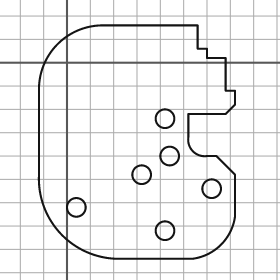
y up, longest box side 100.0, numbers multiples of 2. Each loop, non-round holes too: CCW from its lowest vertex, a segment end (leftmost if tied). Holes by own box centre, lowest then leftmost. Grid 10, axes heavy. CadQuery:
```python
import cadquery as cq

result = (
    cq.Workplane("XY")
    .moveTo(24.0, -84.0)
    .lineTo(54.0, -84.0)
    .threePointArc((66.0, -78.0), (72.0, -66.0))
    .lineTo(72.0, -48.0)
    .lineTo(64.0, -40.0)
    .lineTo(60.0, -40.0)
    .threePointArc((54.0, -38.0), (52.0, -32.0))
    .lineTo(52.0, -22.0)
    .lineTo(68.0, -22.0)
    .lineTo(72.0, -18.0)
    .lineTo(72.0, -12.0)
    .lineTo(68.0, -12.0)
    .lineTo(68.0, 2.0)
    .lineTo(60.0, 2.0)
    .lineTo(60.0, 6.0)
    .lineTo(56.0, 6.0)
    .lineTo(56.0, 16.0)
    .lineTo(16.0, 16.0)
    .threePointArc((-4.0, 8.0), (-12.0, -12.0))
    .lineTo(-12.0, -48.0)
    .threePointArc((-2.0, -74.0), (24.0, -84.0))
    .close()
    .moveTo(42.0, -72.0)
    .circle(4.0)
    .moveTo(4.0, -62.0)
    .circle(4.0)
    .moveTo(62.0, -54.0)
    .circle(4.0)
    .moveTo(32.0, -48.0)
    .circle(4.0)
    .moveTo(44.0, -40.0)
    .circle(4.0)
    .moveTo(42.0, -24.0)
    .circle(4.0)
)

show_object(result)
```